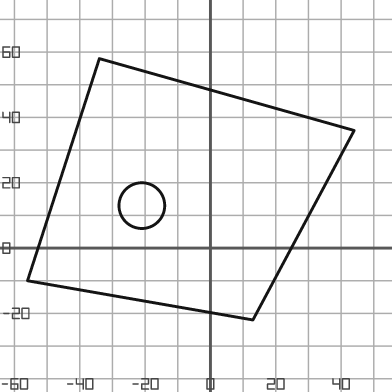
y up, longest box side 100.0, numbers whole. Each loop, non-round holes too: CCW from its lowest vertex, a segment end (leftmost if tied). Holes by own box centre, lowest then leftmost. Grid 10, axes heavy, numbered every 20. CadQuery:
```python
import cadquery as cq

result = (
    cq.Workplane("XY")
    .moveTo(13.0, -22.0)
    .lineTo(44.0, 36.0)
    .lineTo(-34.0, 58.0)
    .lineTo(-56.0, -10.0)
    .close()
    .moveTo(-21.0, 13.0)
    .circle(7.0)
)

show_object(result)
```